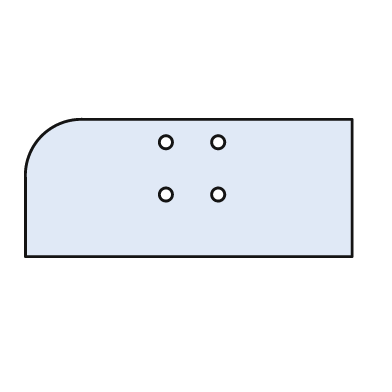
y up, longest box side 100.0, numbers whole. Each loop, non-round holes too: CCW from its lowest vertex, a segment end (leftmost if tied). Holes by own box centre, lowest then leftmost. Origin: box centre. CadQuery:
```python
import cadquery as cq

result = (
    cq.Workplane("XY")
    .moveTo(-50.0, -21.0)
    .lineTo(50.0, -21.0)
    .lineTo(50.0, 21.0)
    .lineTo(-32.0, 21.0)
    .threePointArc((-45.0, 16.0), (-50.0, 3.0))
    .close()
    .moveTo(-7.0, -2.0)
    .circle(2.0)
    .moveTo(9.0, -2.0)
    .circle(2.0)
    .moveTo(-7.0, 14.0)
    .circle(2.0)
    .moveTo(9.0, 14.0)
    .circle(2.0)
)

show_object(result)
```